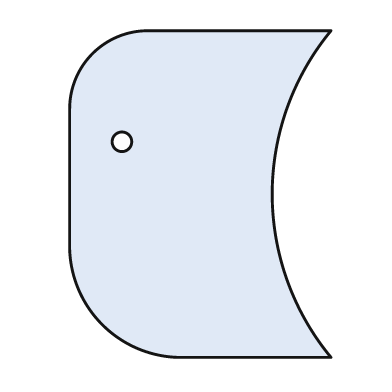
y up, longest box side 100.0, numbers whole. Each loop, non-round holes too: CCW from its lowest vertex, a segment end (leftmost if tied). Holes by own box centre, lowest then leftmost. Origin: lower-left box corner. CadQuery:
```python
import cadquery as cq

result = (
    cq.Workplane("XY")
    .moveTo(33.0, 0.0)
    .lineTo(80.0, 0.0)
    .threePointArc((62.0, 50.0), (80.0, 100.0))
    .lineTo(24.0, 100.0)
    .threePointArc((7.0, 93.0), (0.0, 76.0))
    .lineTo(0.0, 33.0)
    .threePointArc((10.0, 10.0), (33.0, 0.0))
    .close()
    .moveTo(16.0, 66.0)
    .circle(3.0)
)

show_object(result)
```